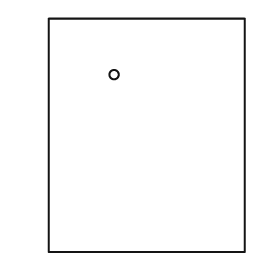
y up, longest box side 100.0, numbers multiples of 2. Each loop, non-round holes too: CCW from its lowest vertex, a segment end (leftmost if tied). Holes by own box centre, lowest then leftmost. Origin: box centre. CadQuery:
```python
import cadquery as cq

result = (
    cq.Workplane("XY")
    .moveTo(-42.0, -50.0)
    .lineTo(42.0, -50.0)
    .lineTo(42.0, 50.0)
    .lineTo(-42.0, 50.0)
    .close()
    .moveTo(-14.0, 26.0)
    .circle(2.0)
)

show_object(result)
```